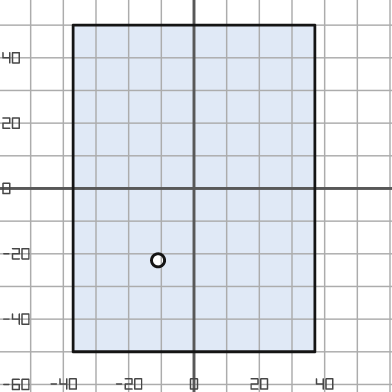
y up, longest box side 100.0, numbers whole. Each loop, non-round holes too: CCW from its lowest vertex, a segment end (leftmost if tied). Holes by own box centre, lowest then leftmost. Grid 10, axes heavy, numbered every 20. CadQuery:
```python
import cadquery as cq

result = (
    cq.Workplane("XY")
    .moveTo(-37.0, -50.0)
    .lineTo(37.0, -50.0)
    .lineTo(37.0, 50.0)
    .lineTo(-37.0, 50.0)
    .close()
    .moveTo(-11.0, -22.0)
    .circle(2.0)
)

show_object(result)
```